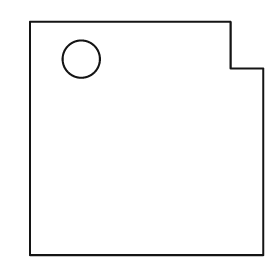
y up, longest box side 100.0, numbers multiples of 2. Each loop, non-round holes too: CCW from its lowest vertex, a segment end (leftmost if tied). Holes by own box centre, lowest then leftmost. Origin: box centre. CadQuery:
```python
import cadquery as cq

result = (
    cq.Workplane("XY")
    .moveTo(-50.0, -50.0)
    .lineTo(50.0, -50.0)
    .lineTo(50.0, 30.0)
    .lineTo(36.0, 30.0)
    .lineTo(36.0, 50.0)
    .lineTo(-50.0, 50.0)
    .close()
    .moveTo(-28.0, 34.0)
    .circle(8.0)
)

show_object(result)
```